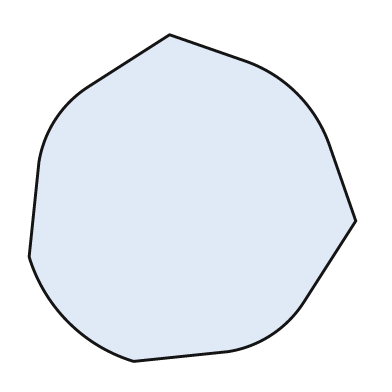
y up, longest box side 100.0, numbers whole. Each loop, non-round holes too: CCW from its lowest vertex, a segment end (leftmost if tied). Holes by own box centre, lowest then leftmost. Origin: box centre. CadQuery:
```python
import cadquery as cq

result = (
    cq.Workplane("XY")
    .moveTo(-18.0, -50.0)
    .lineTo(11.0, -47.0)
    .threePointArc((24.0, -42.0), (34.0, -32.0))
    .lineTo(50.0, -7.0)
    .lineTo(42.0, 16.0)
    .threePointArc((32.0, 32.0), (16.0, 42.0))
    .lineTo(-7.0, 50.0)
    .lineTo(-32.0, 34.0)
    .threePointArc((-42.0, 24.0), (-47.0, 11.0))
    .lineTo(-50.0, -18.0)
    .threePointArc((-38.0, -38.0), (-18.0, -50.0))
    .close()
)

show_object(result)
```